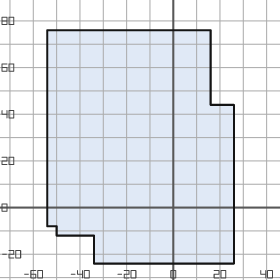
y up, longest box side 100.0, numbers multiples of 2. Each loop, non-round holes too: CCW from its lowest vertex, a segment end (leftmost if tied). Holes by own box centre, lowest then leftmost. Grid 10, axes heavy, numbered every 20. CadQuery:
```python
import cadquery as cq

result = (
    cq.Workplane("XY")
    .moveTo(-34.0, -24.0)
    .lineTo(26.0, -24.0)
    .lineTo(26.0, 44.0)
    .lineTo(16.0, 44.0)
    .lineTo(16.0, 76.0)
    .lineTo(-54.0, 76.0)
    .lineTo(-54.0, -8.0)
    .lineTo(-50.0, -8.0)
    .lineTo(-50.0, -12.0)
    .lineTo(-34.0, -12.0)
    .close()
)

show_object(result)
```